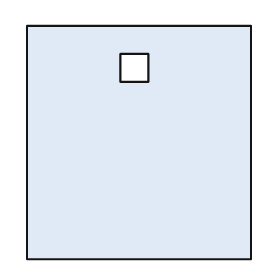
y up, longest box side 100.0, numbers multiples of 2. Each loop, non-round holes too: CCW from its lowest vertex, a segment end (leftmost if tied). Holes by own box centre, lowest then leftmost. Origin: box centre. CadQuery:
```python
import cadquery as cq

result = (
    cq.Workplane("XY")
    .moveTo(-48.0, -50.0)
    .lineTo(48.0, -50.0)
    .lineTo(48.0, 50.0)
    .lineTo(-48.0, 50.0)
    .close()
    .moveTo(-8.0, 26.0)
    .lineTo(4.0, 26.0)
    .lineTo(4.0, 38.0)
    .lineTo(-8.0, 38.0)
    .close()
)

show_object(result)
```